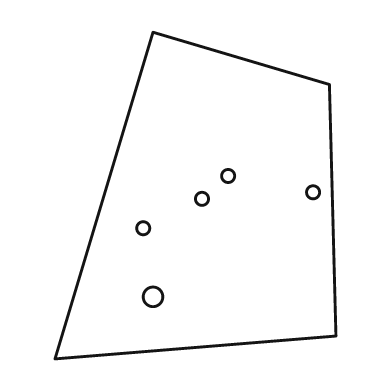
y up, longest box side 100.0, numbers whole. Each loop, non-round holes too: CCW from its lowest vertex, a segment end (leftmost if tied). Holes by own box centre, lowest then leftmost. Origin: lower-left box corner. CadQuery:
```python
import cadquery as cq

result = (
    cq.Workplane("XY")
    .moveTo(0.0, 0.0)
    .lineTo(86.0, 7.0)
    .lineTo(84.0, 84.0)
    .lineTo(30.0, 100.0)
    .close()
    .moveTo(30.0, 19.0)
    .circle(3.0)
    .moveTo(27.0, 40.0)
    .circle(2.0)
    .moveTo(45.0, 49.0)
    .circle(2.0)
    .moveTo(79.0, 51.0)
    .circle(2.0)
    .moveTo(53.0, 56.0)
    .circle(2.0)
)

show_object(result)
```